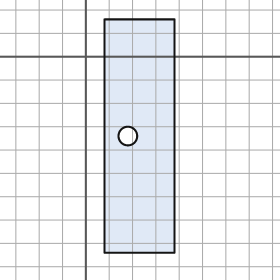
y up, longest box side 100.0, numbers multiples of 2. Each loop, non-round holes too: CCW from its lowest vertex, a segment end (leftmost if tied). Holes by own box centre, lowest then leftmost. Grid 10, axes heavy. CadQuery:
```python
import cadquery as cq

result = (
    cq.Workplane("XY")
    .moveTo(8.0, -84.0)
    .lineTo(38.0, -84.0)
    .lineTo(38.0, 16.0)
    .lineTo(8.0, 16.0)
    .close()
    .moveTo(18.0, -34.0)
    .circle(4.0)
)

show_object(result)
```